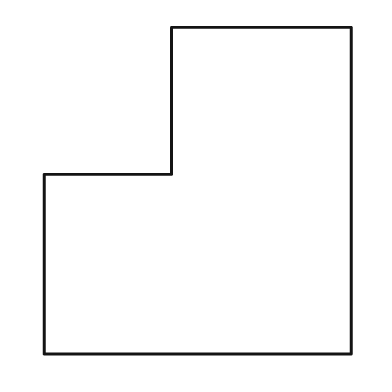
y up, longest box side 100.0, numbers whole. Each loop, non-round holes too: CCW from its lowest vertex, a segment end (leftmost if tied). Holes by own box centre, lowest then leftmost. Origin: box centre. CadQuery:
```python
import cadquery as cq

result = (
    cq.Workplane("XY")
    .moveTo(-47.0, -50.0)
    .lineTo(47.0, -50.0)
    .lineTo(47.0, 50.0)
    .lineTo(-8.0, 50.0)
    .lineTo(-8.0, 5.0)
    .lineTo(-47.0, 5.0)
    .close()
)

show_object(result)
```